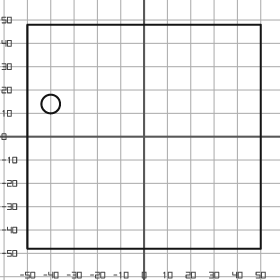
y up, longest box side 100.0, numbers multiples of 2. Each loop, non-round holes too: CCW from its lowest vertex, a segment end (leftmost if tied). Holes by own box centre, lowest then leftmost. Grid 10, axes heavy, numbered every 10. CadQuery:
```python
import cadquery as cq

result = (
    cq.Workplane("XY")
    .moveTo(-50.0, -48.0)
    .lineTo(50.0, -48.0)
    .lineTo(50.0, 48.0)
    .lineTo(-50.0, 48.0)
    .close()
    .moveTo(-40.0, 14.0)
    .circle(4.0)
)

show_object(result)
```